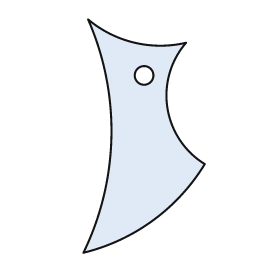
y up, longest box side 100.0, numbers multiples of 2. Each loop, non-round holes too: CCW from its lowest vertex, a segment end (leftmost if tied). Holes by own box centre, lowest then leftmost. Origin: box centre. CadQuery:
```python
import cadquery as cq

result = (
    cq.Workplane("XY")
    .moveTo(-26.0, -50.0)
    .threePointArc((4.0, -36.0), (26.0, -12.0))
    .threePointArc((10.0, 12.0), (18.0, 40.0))
    .threePointArc((-4.0, 40.0), (-24.0, 50.0))
    .threePointArc((-14.0, 0.0), (-26.0, -50.0))
    .close()
    .moveTo(0.0, 26.0)
    .circle(4.0)
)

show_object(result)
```